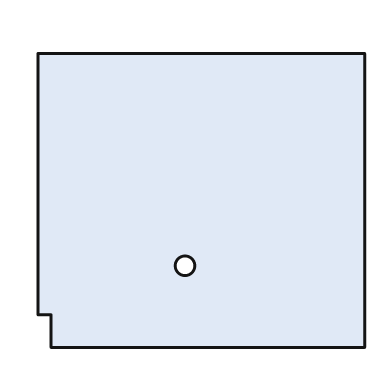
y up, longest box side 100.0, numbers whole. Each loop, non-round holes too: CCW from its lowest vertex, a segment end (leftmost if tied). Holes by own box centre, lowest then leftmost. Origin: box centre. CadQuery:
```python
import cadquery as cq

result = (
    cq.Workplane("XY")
    .moveTo(-46.0, -45.0)
    .lineTo(50.0, -45.0)
    .lineTo(50.0, 45.0)
    .lineTo(-50.0, 45.0)
    .lineTo(-50.0, -35.0)
    .lineTo(-46.0, -35.0)
    .close()
    .moveTo(-5.0, -20.0)
    .circle(3.0)
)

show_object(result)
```